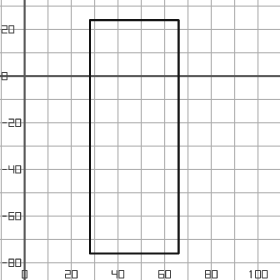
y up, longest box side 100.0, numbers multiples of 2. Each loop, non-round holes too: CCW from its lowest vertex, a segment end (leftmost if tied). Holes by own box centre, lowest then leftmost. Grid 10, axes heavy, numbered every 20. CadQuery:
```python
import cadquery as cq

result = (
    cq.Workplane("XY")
    .moveTo(28.0, -76.0)
    .lineTo(66.0, -76.0)
    .lineTo(66.0, 24.0)
    .lineTo(28.0, 24.0)
    .close()
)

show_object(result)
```